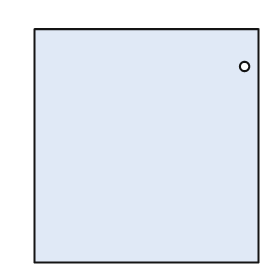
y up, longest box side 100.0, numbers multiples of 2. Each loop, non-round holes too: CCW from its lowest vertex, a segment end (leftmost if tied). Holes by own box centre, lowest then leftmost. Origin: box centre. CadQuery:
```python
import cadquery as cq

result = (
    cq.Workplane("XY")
    .moveTo(-48.0, -50.0)
    .lineTo(48.0, -50.0)
    .lineTo(48.0, 50.0)
    .lineTo(-48.0, 50.0)
    .close()
    .moveTo(42.0, 34.0)
    .circle(2.0)
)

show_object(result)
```